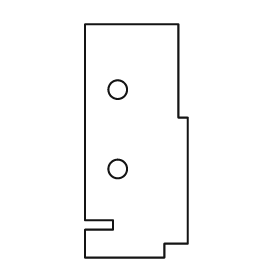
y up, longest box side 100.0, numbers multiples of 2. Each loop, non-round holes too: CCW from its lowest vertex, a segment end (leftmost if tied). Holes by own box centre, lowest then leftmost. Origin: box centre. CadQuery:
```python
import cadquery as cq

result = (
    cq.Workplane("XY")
    .moveTo(-22.0, -50.0)
    .lineTo(12.0, -50.0)
    .lineTo(12.0, -44.0)
    .lineTo(22.0, -44.0)
    .lineTo(22.0, 10.0)
    .lineTo(18.0, 10.0)
    .lineTo(18.0, 50.0)
    .lineTo(-22.0, 50.0)
    .lineTo(-22.0, -34.0)
    .lineTo(-10.0, -34.0)
    .lineTo(-10.0, -38.0)
    .lineTo(-22.0, -38.0)
    .close()
    .moveTo(-8.0, -12.0)
    .circle(4.0)
    .moveTo(-8.0, 22.0)
    .circle(4.0)
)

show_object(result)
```